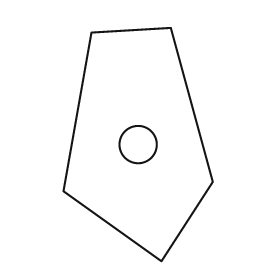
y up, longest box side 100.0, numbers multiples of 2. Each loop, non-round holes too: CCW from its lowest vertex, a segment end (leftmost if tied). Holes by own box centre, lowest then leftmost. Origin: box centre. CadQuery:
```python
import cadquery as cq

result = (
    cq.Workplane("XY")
    .moveTo(10.0, -50.0)
    .lineTo(32.0, -16.0)
    .lineTo(14.0, 50.0)
    .lineTo(-20.0, 48.0)
    .lineTo(-32.0, -20.0)
    .close()
    .moveTo(0.0, 0.0)
    .circle(8.0)
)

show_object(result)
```